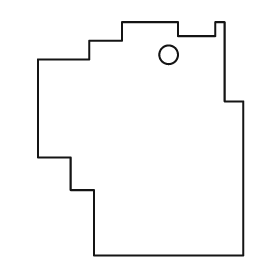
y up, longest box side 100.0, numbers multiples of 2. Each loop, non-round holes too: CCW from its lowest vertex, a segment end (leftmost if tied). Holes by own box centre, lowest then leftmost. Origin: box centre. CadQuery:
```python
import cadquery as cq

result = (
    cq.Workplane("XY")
    .moveTo(-20.0, -50.0)
    .lineTo(44.0, -50.0)
    .lineTo(44.0, 16.0)
    .lineTo(36.0, 16.0)
    .lineTo(36.0, 50.0)
    .lineTo(32.0, 50.0)
    .lineTo(32.0, 44.0)
    .lineTo(16.0, 44.0)
    .lineTo(16.0, 50.0)
    .lineTo(-8.0, 50.0)
    .lineTo(-8.0, 42.0)
    .lineTo(-22.0, 42.0)
    .lineTo(-22.0, 34.0)
    .lineTo(-44.0, 34.0)
    .lineTo(-44.0, -8.0)
    .lineTo(-30.0, -8.0)
    .lineTo(-30.0, -22.0)
    .lineTo(-20.0, -22.0)
    .close()
    .moveTo(12.0, 36.0)
    .circle(4.0)
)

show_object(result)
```